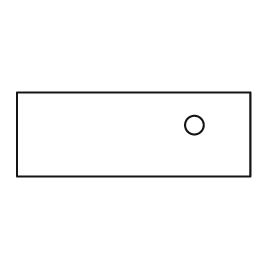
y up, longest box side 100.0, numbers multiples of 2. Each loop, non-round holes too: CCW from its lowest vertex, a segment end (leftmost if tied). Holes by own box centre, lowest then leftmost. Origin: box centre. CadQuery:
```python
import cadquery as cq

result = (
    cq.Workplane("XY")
    .moveTo(-50.0, -18.0)
    .lineTo(50.0, -18.0)
    .lineTo(50.0, 18.0)
    .lineTo(-50.0, 18.0)
    .close()
    .moveTo(26.0, 4.0)
    .circle(4.0)
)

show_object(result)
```